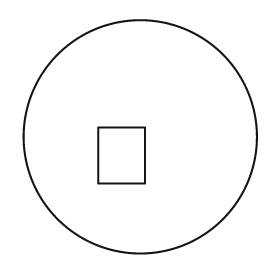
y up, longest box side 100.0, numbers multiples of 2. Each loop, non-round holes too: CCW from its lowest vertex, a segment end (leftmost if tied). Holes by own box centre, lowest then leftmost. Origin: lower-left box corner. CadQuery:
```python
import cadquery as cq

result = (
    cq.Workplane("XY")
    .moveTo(50.0, 50.0)
    .circle(50.0)
    .moveTo(32.0, 30.0)
    .lineTo(52.0, 30.0)
    .lineTo(52.0, 54.0)
    .lineTo(32.0, 54.0)
    .close()
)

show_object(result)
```